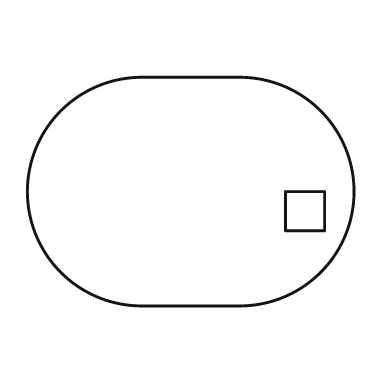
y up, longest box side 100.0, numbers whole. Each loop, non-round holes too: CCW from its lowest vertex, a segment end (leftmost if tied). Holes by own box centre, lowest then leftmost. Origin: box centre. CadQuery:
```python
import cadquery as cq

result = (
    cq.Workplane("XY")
    .moveTo(-15.0, -35.0)
    .lineTo(15.0, -35.0)
    .threePointArc((50.0, 0.0), (15.0, 35.0))
    .lineTo(-15.0, 35.0)
    .threePointArc((-50.0, 0.0), (-15.0, -35.0))
    .close()
    .moveTo(29.0, -12.0)
    .lineTo(41.0, -12.0)
    .lineTo(41.0, 0.0)
    .lineTo(29.0, 0.0)
    .close()
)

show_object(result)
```